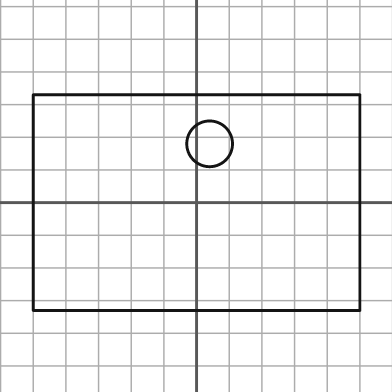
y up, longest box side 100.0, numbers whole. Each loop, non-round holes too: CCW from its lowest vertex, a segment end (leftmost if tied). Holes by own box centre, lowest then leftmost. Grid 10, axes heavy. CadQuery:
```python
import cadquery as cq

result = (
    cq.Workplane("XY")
    .moveTo(-50.0, -33.0)
    .lineTo(50.0, -33.0)
    .lineTo(50.0, 33.0)
    .lineTo(-50.0, 33.0)
    .close()
    .moveTo(4.0, 18.0)
    .circle(7.0)
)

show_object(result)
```